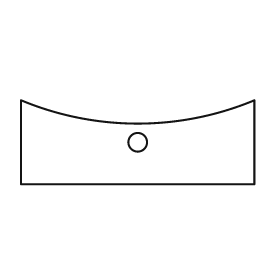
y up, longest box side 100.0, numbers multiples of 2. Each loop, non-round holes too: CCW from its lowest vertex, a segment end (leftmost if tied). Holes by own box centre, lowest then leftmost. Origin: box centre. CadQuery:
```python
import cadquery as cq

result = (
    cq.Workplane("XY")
    .moveTo(-50.0, -18.0)
    .lineTo(50.0, -18.0)
    .lineTo(50.0, 18.0)
    .threePointArc((0.0, 8.0), (-50.0, 18.0))
    .close()
    .moveTo(0.0, 0.0)
    .circle(4.0)
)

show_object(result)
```